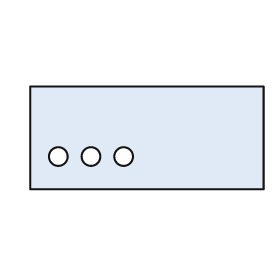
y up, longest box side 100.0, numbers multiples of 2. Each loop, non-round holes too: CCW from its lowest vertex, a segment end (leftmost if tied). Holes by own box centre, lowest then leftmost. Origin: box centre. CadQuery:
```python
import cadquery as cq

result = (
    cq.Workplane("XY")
    .moveTo(-50.0, -22.0)
    .lineTo(50.0, -22.0)
    .lineTo(50.0, 22.0)
    .lineTo(-50.0, 22.0)
    .close()
    .moveTo(-38.0, -8.0)
    .circle(4.0)
    .moveTo(-24.0, -8.0)
    .circle(4.0)
    .moveTo(-10.0, -8.0)
    .circle(4.0)
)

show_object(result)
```